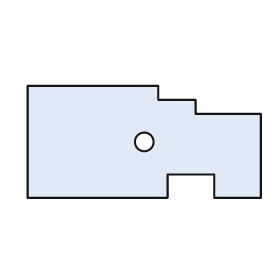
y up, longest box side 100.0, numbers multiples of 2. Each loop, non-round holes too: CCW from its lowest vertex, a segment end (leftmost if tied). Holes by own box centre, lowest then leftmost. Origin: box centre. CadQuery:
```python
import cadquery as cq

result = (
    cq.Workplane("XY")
    .moveTo(-50.0, -24.0)
    .lineTo(10.0, -24.0)
    .lineTo(10.0, -14.0)
    .lineTo(30.0, -14.0)
    .lineTo(30.0, -24.0)
    .lineTo(50.0, -24.0)
    .lineTo(50.0, 12.0)
    .lineTo(22.0, 12.0)
    .lineTo(22.0, 18.0)
    .lineTo(6.0, 18.0)
    .lineTo(6.0, 24.0)
    .lineTo(-50.0, 24.0)
    .close()
    .moveTo(0.0, 0.0)
    .circle(4.0)
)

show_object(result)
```